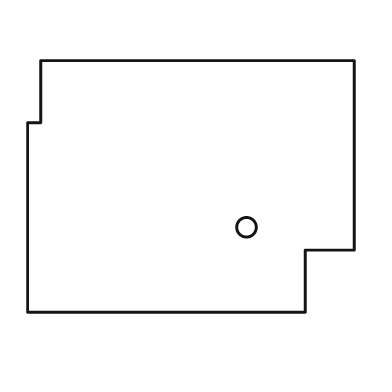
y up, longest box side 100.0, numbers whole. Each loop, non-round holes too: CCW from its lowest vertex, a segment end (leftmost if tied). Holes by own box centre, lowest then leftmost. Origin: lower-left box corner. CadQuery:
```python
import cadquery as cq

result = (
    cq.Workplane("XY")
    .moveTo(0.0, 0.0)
    .lineTo(85.0, 0.0)
    .lineTo(85.0, 19.0)
    .lineTo(100.0, 19.0)
    .lineTo(100.0, 77.0)
    .lineTo(4.0, 77.0)
    .lineTo(4.0, 58.0)
    .lineTo(0.0, 58.0)
    .close()
    .moveTo(67.0, 26.0)
    .circle(3.0)
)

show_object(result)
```